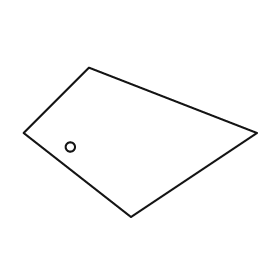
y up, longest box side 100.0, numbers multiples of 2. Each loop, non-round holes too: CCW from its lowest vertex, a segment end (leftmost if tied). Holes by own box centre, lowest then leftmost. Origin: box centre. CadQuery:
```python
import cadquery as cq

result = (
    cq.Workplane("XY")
    .moveTo(-4.0, -32.0)
    .lineTo(50.0, 4.0)
    .lineTo(-22.0, 32.0)
    .lineTo(-50.0, 4.0)
    .close()
    .moveTo(-30.0, -2.0)
    .circle(2.0)
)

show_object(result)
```